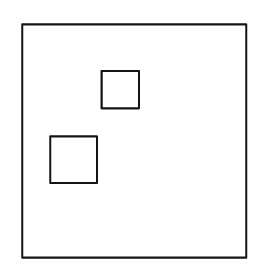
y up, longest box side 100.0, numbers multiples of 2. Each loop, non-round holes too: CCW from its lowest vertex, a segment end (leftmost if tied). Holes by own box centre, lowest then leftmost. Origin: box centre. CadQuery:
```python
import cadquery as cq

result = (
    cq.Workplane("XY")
    .moveTo(-48.0, -50.0)
    .lineTo(48.0, -50.0)
    .lineTo(48.0, 50.0)
    .lineTo(-48.0, 50.0)
    .close()
    .moveTo(-36.0, -18.0)
    .lineTo(-16.0, -18.0)
    .lineTo(-16.0, 2.0)
    .lineTo(-36.0, 2.0)
    .close()
    .moveTo(-14.0, 14.0)
    .lineTo(2.0, 14.0)
    .lineTo(2.0, 30.0)
    .lineTo(-14.0, 30.0)
    .close()
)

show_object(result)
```